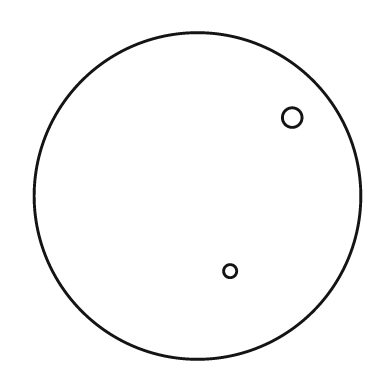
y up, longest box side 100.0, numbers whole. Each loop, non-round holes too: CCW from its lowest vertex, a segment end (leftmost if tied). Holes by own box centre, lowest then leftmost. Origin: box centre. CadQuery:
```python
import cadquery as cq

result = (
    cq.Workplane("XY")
    .moveTo(0.0, 0.0)
    .circle(50.0)
    .moveTo(10.0, -23.0)
    .circle(2.0)
    .moveTo(29.0, 24.0)
    .circle(3.0)
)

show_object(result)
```